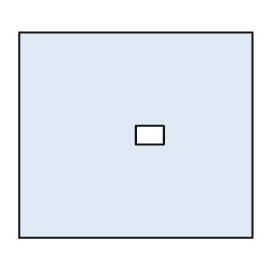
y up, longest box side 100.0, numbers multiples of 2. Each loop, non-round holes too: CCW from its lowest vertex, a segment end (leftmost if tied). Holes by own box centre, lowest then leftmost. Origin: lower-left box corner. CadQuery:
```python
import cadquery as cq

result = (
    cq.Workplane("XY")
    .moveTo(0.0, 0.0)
    .lineTo(100.0, 0.0)
    .lineTo(100.0, 88.0)
    .lineTo(0.0, 88.0)
    .close()
    .moveTo(50.0, 40.0)
    .lineTo(62.0, 40.0)
    .lineTo(62.0, 48.0)
    .lineTo(50.0, 48.0)
    .close()
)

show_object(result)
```